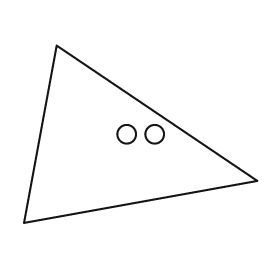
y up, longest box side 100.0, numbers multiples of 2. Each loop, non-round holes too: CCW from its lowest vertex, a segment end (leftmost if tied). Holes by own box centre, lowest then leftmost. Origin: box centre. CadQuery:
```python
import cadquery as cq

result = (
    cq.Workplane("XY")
    .moveTo(-50.0, -38.0)
    .lineTo(50.0, -20.0)
    .lineTo(-36.0, 38.0)
    .close()
    .moveTo(-6.0, 0.0)
    .circle(4.0)
    .moveTo(6.0, 0.0)
    .circle(4.0)
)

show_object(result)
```